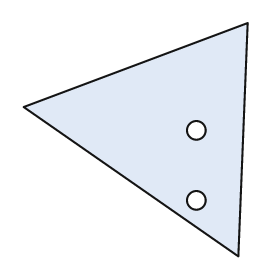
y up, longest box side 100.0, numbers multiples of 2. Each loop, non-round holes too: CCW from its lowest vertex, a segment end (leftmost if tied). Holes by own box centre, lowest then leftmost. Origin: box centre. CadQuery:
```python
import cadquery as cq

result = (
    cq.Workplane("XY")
    .moveTo(44.0, -50.0)
    .lineTo(48.0, 50.0)
    .lineTo(-48.0, 14.0)
    .close()
    .moveTo(26.0, -26.0)
    .circle(4.0)
    .moveTo(26.0, 4.0)
    .circle(4.0)
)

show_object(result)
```